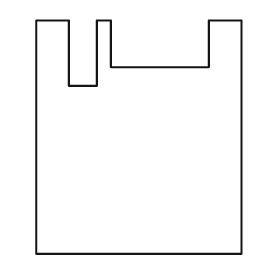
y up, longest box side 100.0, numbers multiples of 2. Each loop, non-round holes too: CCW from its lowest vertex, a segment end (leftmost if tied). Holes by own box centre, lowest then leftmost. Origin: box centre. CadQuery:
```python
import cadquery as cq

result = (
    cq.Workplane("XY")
    .moveTo(-44.0, -50.0)
    .lineTo(44.0, -50.0)
    .lineTo(44.0, 50.0)
    .lineTo(30.0, 50.0)
    .lineTo(30.0, 30.0)
    .lineTo(-12.0, 30.0)
    .lineTo(-12.0, 50.0)
    .lineTo(-18.0, 50.0)
    .lineTo(-18.0, 22.0)
    .lineTo(-30.0, 22.0)
    .lineTo(-30.0, 50.0)
    .lineTo(-44.0, 50.0)
    .close()
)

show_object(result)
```